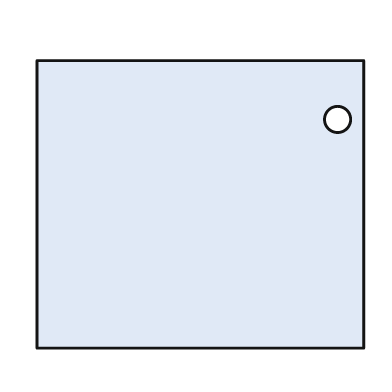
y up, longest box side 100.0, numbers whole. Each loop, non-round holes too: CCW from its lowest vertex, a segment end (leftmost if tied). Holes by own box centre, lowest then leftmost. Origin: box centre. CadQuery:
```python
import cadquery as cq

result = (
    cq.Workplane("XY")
    .moveTo(-50.0, -44.0)
    .lineTo(50.0, -44.0)
    .lineTo(50.0, 44.0)
    .lineTo(-50.0, 44.0)
    .close()
    .moveTo(42.0, 26.0)
    .circle(4.0)
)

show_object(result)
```